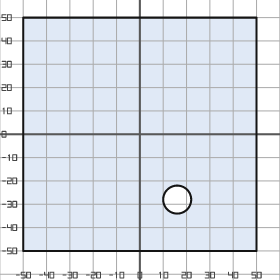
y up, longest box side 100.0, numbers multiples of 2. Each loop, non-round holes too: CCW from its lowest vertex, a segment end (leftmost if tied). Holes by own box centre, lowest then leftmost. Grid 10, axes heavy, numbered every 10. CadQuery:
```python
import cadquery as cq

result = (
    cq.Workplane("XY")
    .moveTo(-50.0, -50.0)
    .lineTo(50.0, -50.0)
    .lineTo(50.0, 50.0)
    .lineTo(-50.0, 50.0)
    .close()
    .moveTo(16.0, -28.0)
    .circle(6.0)
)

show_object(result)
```